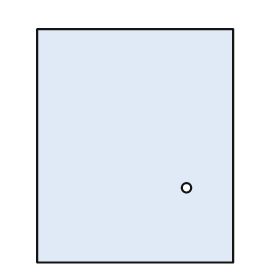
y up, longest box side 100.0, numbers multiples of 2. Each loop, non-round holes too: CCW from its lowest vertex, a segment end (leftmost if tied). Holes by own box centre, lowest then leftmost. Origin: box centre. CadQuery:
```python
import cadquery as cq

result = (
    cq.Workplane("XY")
    .moveTo(-42.0, -50.0)
    .lineTo(42.0, -50.0)
    .lineTo(42.0, 50.0)
    .lineTo(-42.0, 50.0)
    .close()
    .moveTo(22.0, -18.0)
    .circle(2.0)
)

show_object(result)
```